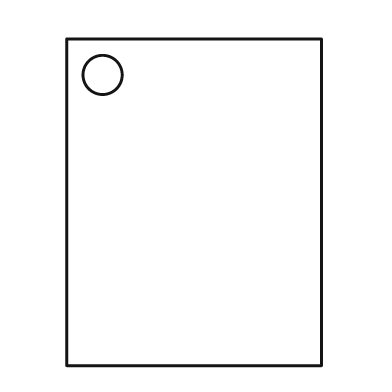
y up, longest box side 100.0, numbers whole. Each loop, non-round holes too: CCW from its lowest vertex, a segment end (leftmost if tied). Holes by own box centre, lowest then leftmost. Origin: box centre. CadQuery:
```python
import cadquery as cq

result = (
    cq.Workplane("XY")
    .moveTo(-39.0, -50.0)
    .lineTo(39.0, -50.0)
    .lineTo(39.0, 50.0)
    .lineTo(-39.0, 50.0)
    .close()
    .moveTo(-28.0, 39.0)
    .circle(6.0)
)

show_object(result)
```